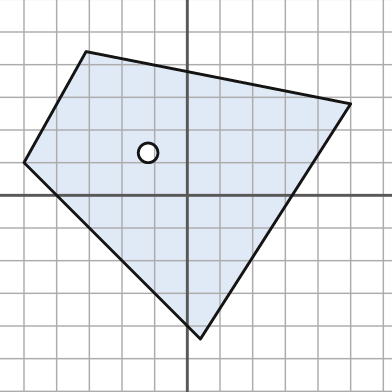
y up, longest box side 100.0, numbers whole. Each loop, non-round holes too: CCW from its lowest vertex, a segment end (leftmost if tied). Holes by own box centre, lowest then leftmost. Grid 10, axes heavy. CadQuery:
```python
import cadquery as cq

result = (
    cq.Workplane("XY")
    .moveTo(4.0, -44.0)
    .lineTo(50.0, 28.0)
    .lineTo(-31.0, 44.0)
    .lineTo(-50.0, 10.0)
    .close()
    .moveTo(-12.0, 13.0)
    .circle(3.0)
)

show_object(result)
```